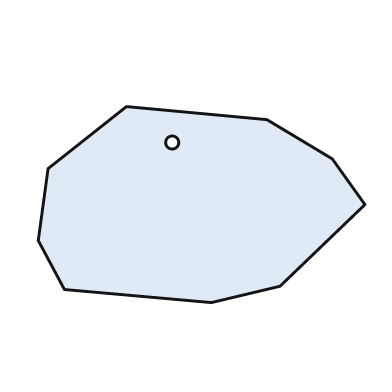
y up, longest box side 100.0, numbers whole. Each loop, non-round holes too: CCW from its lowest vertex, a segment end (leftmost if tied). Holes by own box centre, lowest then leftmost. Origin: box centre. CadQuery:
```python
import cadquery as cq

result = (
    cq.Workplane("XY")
    .moveTo(3.0, -30.0)
    .lineTo(24.0, -25.0)
    .lineTo(50.0, 0.0)
    .lineTo(40.0, 14.0)
    .lineTo(20.0, 26.0)
    .lineTo(-23.0, 30.0)
    .lineTo(-47.0, 11.0)
    .lineTo(-50.0, -11.0)
    .lineTo(-42.0, -26.0)
    .close()
    .moveTo(-9.0, 19.0)
    .circle(2.0)
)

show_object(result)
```